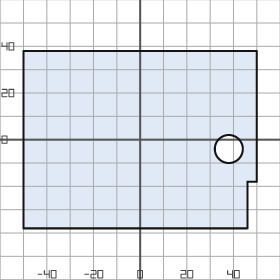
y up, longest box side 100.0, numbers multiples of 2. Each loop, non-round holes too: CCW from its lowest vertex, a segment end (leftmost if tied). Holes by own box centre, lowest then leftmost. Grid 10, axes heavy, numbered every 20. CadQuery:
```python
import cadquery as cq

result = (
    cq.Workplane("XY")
    .moveTo(-50.0, -38.0)
    .lineTo(46.0, -38.0)
    .lineTo(46.0, -18.0)
    .lineTo(50.0, -18.0)
    .lineTo(50.0, 38.0)
    .lineTo(-50.0, 38.0)
    .close()
    .moveTo(38.0, -4.0)
    .circle(6.0)
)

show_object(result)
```